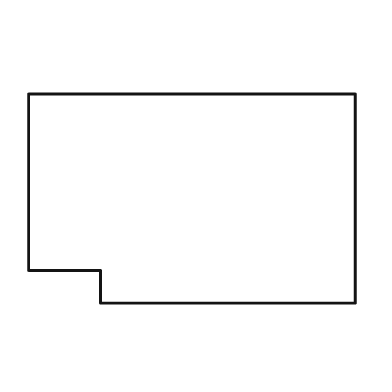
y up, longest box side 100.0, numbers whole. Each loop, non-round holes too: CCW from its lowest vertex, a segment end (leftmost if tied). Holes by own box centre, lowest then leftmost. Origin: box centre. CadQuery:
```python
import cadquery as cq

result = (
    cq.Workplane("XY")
    .moveTo(-28.0, -32.0)
    .lineTo(50.0, -32.0)
    .lineTo(50.0, 32.0)
    .lineTo(-50.0, 32.0)
    .lineTo(-50.0, -22.0)
    .lineTo(-28.0, -22.0)
    .close()
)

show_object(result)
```